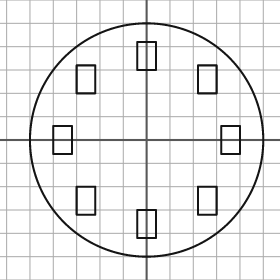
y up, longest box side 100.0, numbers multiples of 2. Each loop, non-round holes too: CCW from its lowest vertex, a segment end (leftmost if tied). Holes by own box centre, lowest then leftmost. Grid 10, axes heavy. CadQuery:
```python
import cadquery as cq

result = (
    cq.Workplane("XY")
    .moveTo(0.0, 0.0)
    .circle(50.0)
    .moveTo(-4.0, -42.0)
    .lineTo(4.0, -42.0)
    .lineTo(4.0, -30.0)
    .lineTo(-4.0, -30.0)
    .close()
    .moveTo(-30.0, -32.0)
    .lineTo(-22.0, -32.0)
    .lineTo(-22.0, -20.0)
    .lineTo(-30.0, -20.0)
    .close()
    .moveTo(22.0, -32.0)
    .lineTo(30.0, -32.0)
    .lineTo(30.0, -20.0)
    .lineTo(22.0, -20.0)
    .close()
    .moveTo(-40.0, -6.0)
    .lineTo(-32.0, -6.0)
    .lineTo(-32.0, 6.0)
    .lineTo(-40.0, 6.0)
    .close()
    .moveTo(32.0, -6.0)
    .lineTo(40.0, -6.0)
    .lineTo(40.0, 6.0)
    .lineTo(32.0, 6.0)
    .close()
    .moveTo(-30.0, 20.0)
    .lineTo(-22.0, 20.0)
    .lineTo(-22.0, 32.0)
    .lineTo(-30.0, 32.0)
    .close()
    .moveTo(22.0, 20.0)
    .lineTo(30.0, 20.0)
    .lineTo(30.0, 32.0)
    .lineTo(22.0, 32.0)
    .close()
    .moveTo(-4.0, 30.0)
    .lineTo(4.0, 30.0)
    .lineTo(4.0, 42.0)
    .lineTo(-4.0, 42.0)
    .close()
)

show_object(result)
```